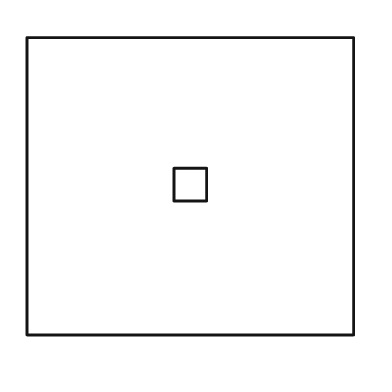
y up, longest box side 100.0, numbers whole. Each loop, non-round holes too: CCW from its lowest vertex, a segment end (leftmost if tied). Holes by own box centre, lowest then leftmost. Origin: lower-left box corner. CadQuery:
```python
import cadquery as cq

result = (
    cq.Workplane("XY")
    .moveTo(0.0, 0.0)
    .lineTo(100.0, 0.0)
    .lineTo(100.0, 91.0)
    .lineTo(0.0, 91.0)
    .close()
    .moveTo(45.0, 41.0)
    .lineTo(55.0, 41.0)
    .lineTo(55.0, 51.0)
    .lineTo(45.0, 51.0)
    .close()
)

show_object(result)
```